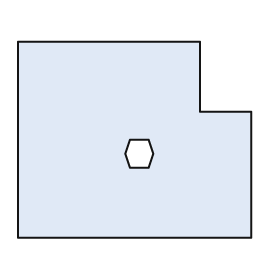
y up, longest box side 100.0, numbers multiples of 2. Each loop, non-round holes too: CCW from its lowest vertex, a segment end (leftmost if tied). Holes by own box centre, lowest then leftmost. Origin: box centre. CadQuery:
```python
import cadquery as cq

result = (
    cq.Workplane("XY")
    .moveTo(-50.0, -42.0)
    .lineTo(50.0, -42.0)
    .lineTo(50.0, 12.0)
    .lineTo(28.0, 12.0)
    .lineTo(28.0, 42.0)
    .lineTo(-50.0, 42.0)
    .close()
    .moveTo(-2.0, -12.0)
    .lineTo(6.0, -12.0)
    .lineTo(8.0, -6.0)
    .lineTo(6.0, 0.0)
    .lineTo(-2.0, 0.0)
    .lineTo(-4.0, -6.0)
    .close()
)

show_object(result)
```